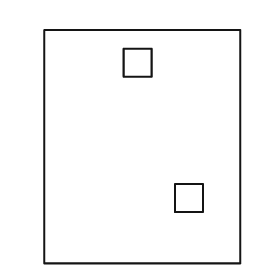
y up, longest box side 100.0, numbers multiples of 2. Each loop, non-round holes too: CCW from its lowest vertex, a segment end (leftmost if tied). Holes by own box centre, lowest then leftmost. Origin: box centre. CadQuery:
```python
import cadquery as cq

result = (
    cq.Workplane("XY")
    .moveTo(-42.0, -50.0)
    .lineTo(42.0, -50.0)
    .lineTo(42.0, 50.0)
    .lineTo(-42.0, 50.0)
    .close()
    .moveTo(14.0, -28.0)
    .lineTo(26.0, -28.0)
    .lineTo(26.0, -16.0)
    .lineTo(14.0, -16.0)
    .close()
    .moveTo(-8.0, 30.0)
    .lineTo(4.0, 30.0)
    .lineTo(4.0, 42.0)
    .lineTo(-8.0, 42.0)
    .close()
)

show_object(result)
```